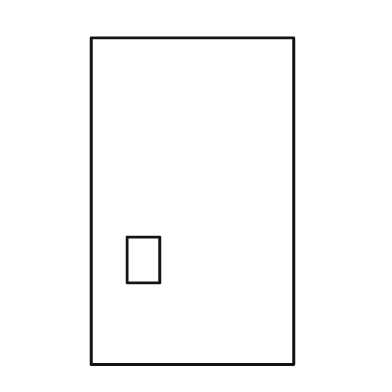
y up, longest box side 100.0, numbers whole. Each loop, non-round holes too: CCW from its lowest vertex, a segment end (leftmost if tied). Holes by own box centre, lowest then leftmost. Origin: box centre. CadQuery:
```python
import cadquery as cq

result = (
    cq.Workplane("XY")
    .moveTo(-31.0, -50.0)
    .lineTo(31.0, -50.0)
    .lineTo(31.0, 50.0)
    .lineTo(-31.0, 50.0)
    .close()
    .moveTo(-20.0, -25.0)
    .lineTo(-10.0, -25.0)
    .lineTo(-10.0, -11.0)
    .lineTo(-20.0, -11.0)
    .close()
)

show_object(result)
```